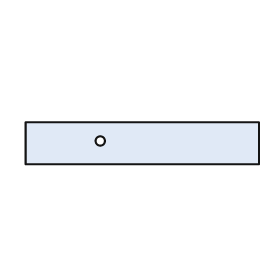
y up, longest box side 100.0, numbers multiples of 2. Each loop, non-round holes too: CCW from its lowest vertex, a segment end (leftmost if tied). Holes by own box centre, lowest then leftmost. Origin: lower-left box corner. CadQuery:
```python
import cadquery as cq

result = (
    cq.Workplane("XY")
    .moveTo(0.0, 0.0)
    .lineTo(100.0, 0.0)
    .lineTo(100.0, 18.0)
    .lineTo(0.0, 18.0)
    .close()
    .moveTo(32.0, 10.0)
    .circle(2.0)
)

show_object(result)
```